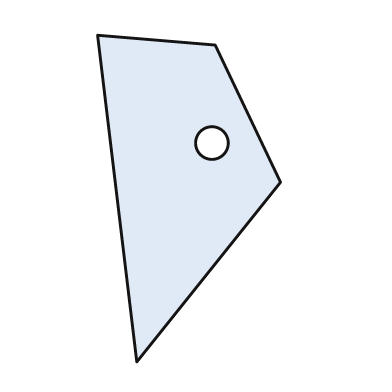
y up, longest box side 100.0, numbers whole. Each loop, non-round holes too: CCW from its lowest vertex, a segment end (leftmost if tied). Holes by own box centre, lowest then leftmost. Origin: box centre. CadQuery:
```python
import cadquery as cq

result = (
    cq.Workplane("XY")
    .moveTo(-16.0, -50.0)
    .lineTo(28.0, 5.0)
    .lineTo(8.0, 47.0)
    .lineTo(-28.0, 50.0)
    .close()
    .moveTo(7.0, 17.0)
    .circle(5.0)
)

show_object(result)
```